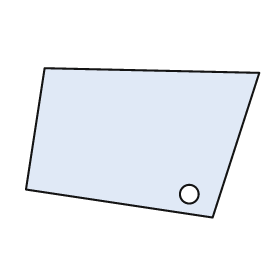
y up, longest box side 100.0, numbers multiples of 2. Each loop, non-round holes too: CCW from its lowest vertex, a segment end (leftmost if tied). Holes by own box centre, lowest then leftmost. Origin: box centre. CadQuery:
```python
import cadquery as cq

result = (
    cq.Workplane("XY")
    .moveTo(30.0, -32.0)
    .lineTo(50.0, 30.0)
    .lineTo(-42.0, 32.0)
    .lineTo(-50.0, -20.0)
    .close()
    .moveTo(20.0, -22.0)
    .circle(4.0)
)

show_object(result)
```